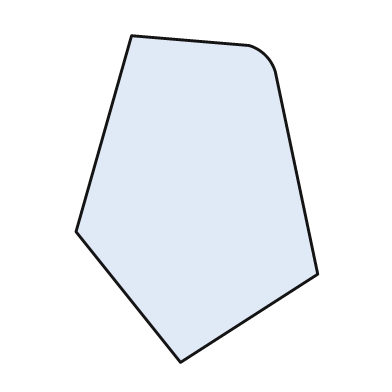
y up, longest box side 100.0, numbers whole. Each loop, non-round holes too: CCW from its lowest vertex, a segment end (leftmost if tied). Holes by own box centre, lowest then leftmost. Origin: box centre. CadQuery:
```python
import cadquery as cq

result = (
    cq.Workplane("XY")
    .moveTo(-5.0, -50.0)
    .lineTo(37.0, -23.0)
    .lineTo(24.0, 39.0)
    .threePointArc((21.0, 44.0), (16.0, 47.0))
    .lineTo(-20.0, 50.0)
    .lineTo(-37.0, -10.0)
    .close()
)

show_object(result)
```